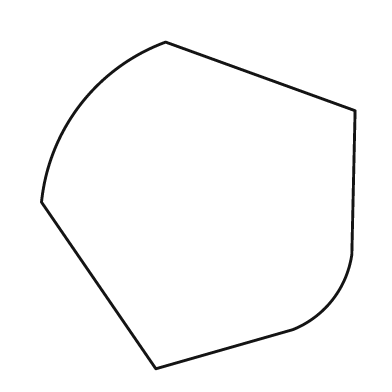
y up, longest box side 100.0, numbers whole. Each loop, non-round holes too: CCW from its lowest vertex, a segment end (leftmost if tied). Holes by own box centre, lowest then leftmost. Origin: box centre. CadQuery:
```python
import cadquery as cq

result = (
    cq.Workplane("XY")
    .moveTo(-13.0, -50.0)
    .lineTo(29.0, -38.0)
    .threePointArc((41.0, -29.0), (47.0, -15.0))
    .lineTo(48.0, 29.0)
    .lineTo(-10.0, 50.0)
    .threePointArc((-36.0, 31.0), (-48.0, 1.0))
    .close()
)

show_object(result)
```